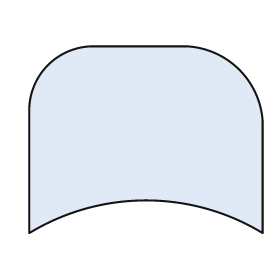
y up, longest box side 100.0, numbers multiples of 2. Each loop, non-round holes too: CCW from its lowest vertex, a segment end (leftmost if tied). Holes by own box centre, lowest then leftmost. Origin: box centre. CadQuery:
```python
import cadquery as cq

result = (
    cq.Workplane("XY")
    .moveTo(-50.0, -40.0)
    .threePointArc((0.0, -26.0), (50.0, -40.0))
    .lineTo(50.0, 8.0)
    .threePointArc((40.0, 30.0), (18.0, 40.0))
    .lineTo(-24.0, 40.0)
    .threePointArc((-42.0, 32.0), (-50.0, 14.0))
    .close()
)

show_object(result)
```